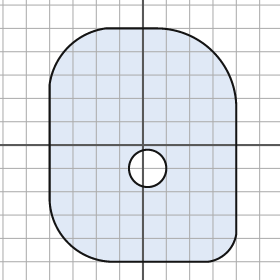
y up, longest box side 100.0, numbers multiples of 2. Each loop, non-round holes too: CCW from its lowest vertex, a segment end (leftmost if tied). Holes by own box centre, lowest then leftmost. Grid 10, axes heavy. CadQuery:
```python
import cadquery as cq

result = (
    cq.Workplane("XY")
    .moveTo(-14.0, -50.0)
    .lineTo(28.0, -50.0)
    .threePointArc((36.0, -46.0), (40.0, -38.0))
    .lineTo(40.0, 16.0)
    .threePointArc((30.0, 40.0), (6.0, 50.0))
    .lineTo(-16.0, 50.0)
    .threePointArc((-32.0, 42.0), (-40.0, 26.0))
    .lineTo(-40.0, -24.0)
    .threePointArc((-32.0, -42.0), (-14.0, -50.0))
    .close()
    .moveTo(2.0, -10.0)
    .circle(8.0)
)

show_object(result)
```